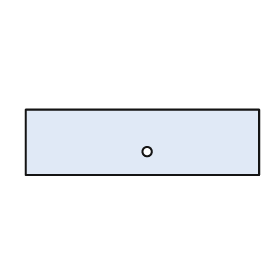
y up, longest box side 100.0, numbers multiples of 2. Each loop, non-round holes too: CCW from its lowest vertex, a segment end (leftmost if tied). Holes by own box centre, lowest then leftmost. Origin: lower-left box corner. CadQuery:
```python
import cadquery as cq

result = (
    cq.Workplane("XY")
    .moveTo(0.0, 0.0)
    .lineTo(100.0, 0.0)
    .lineTo(100.0, 28.0)
    .lineTo(0.0, 28.0)
    .close()
    .moveTo(52.0, 10.0)
    .circle(2.0)
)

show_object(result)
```